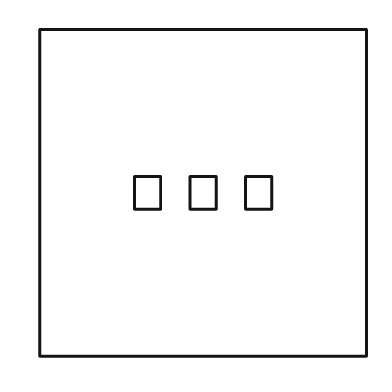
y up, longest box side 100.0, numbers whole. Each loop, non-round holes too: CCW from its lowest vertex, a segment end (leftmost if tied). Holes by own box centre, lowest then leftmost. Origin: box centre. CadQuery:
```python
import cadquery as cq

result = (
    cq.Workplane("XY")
    .moveTo(-50.0, -50.0)
    .lineTo(50.0, -50.0)
    .lineTo(50.0, 50.0)
    .lineTo(-50.0, 50.0)
    .close()
    .moveTo(-21.0, -5.0)
    .lineTo(-13.0, -5.0)
    .lineTo(-13.0, 5.0)
    .lineTo(-21.0, 5.0)
    .close()
    .moveTo(-4.0, -5.0)
    .lineTo(4.0, -5.0)
    .lineTo(4.0, 5.0)
    .lineTo(-4.0, 5.0)
    .close()
    .moveTo(13.0, -5.0)
    .lineTo(21.0, -5.0)
    .lineTo(21.0, 5.0)
    .lineTo(13.0, 5.0)
    .close()
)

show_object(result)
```